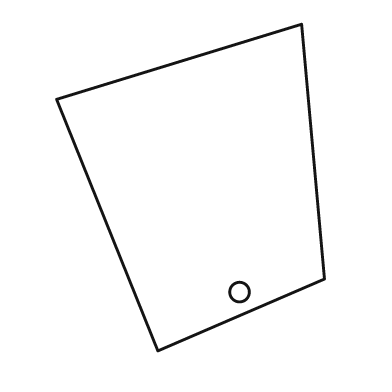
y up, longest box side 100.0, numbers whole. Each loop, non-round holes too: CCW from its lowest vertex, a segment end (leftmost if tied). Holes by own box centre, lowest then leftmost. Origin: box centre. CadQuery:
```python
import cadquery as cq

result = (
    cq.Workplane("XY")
    .moveTo(-10.0, -50.0)
    .lineTo(41.0, -28.0)
    .lineTo(34.0, 50.0)
    .lineTo(-41.0, 27.0)
    .close()
    .moveTo(15.0, -32.0)
    .circle(3.0)
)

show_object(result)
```